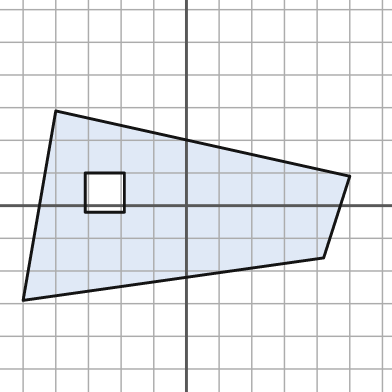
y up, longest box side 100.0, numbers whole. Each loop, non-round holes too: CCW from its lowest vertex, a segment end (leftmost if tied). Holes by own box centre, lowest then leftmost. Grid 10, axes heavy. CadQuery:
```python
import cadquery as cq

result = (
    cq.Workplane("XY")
    .moveTo(-50.0, -29.0)
    .lineTo(42.0, -16.0)
    .lineTo(50.0, 9.0)
    .lineTo(-40.0, 29.0)
    .close()
    .moveTo(-31.0, -2.0)
    .lineTo(-19.0, -2.0)
    .lineTo(-19.0, 10.0)
    .lineTo(-31.0, 10.0)
    .close()
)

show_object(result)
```